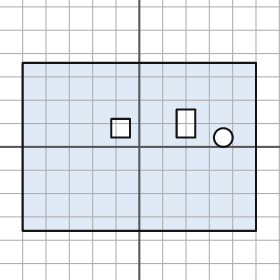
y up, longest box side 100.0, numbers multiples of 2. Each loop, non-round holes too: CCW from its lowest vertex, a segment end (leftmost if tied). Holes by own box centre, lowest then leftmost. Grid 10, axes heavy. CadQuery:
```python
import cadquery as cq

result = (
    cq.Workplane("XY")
    .moveTo(-50.0, -36.0)
    .lineTo(50.0, -36.0)
    .lineTo(50.0, 36.0)
    .lineTo(-50.0, 36.0)
    .close()
    .moveTo(36.0, 4.0)
    .circle(4.0)
    .moveTo(-12.0, 4.0)
    .lineTo(-4.0, 4.0)
    .lineTo(-4.0, 12.0)
    .lineTo(-12.0, 12.0)
    .close()
    .moveTo(16.0, 4.0)
    .lineTo(24.0, 4.0)
    .lineTo(24.0, 16.0)
    .lineTo(16.0, 16.0)
    .close()
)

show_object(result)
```